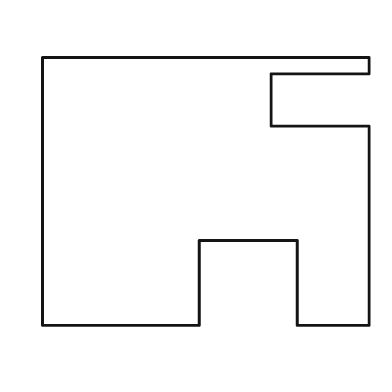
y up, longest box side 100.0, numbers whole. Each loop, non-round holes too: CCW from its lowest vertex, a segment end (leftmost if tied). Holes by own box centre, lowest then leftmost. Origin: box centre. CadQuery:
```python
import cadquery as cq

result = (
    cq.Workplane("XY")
    .moveTo(-50.0, -41.0)
    .lineTo(-2.0, -41.0)
    .lineTo(-2.0, -15.0)
    .lineTo(28.0, -15.0)
    .lineTo(28.0, -41.0)
    .lineTo(50.0, -41.0)
    .lineTo(50.0, 20.0)
    .lineTo(20.0, 20.0)
    .lineTo(20.0, 36.0)
    .lineTo(50.0, 36.0)
    .lineTo(50.0, 41.0)
    .lineTo(-50.0, 41.0)
    .close()
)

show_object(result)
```